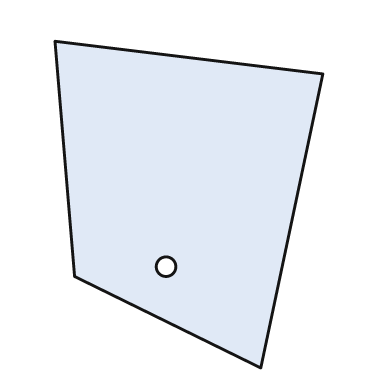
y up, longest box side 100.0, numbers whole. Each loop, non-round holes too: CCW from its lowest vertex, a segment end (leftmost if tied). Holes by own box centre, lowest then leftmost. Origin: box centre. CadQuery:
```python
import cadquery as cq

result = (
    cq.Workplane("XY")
    .moveTo(22.0, -50.0)
    .lineTo(41.0, 40.0)
    .lineTo(-41.0, 50.0)
    .lineTo(-35.0, -22.0)
    .close()
    .moveTo(-7.0, -19.0)
    .circle(3.0)
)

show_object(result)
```